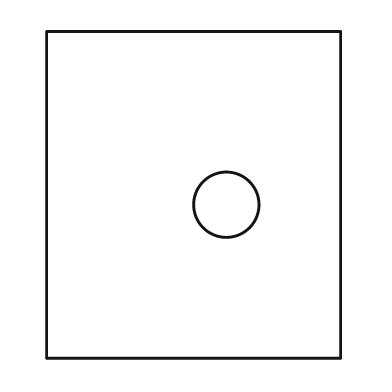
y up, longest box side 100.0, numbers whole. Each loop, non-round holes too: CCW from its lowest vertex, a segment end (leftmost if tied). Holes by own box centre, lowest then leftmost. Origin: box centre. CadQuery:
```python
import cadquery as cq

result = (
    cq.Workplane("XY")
    .moveTo(-45.0, -50.0)
    .lineTo(45.0, -50.0)
    .lineTo(45.0, 50.0)
    .lineTo(-45.0, 50.0)
    .close()
    .moveTo(10.0, -3.0)
    .circle(10.0)
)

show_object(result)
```